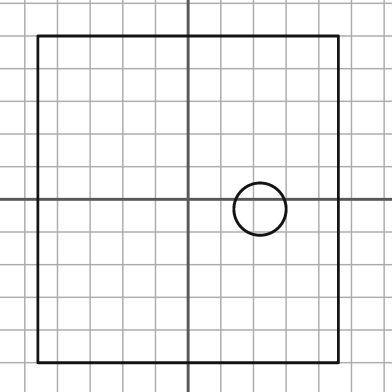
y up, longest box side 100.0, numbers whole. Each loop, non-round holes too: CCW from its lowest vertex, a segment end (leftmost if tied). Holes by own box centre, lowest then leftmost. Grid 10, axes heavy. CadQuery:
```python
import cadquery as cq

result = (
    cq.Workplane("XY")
    .moveTo(-46.0, -50.0)
    .lineTo(46.0, -50.0)
    .lineTo(46.0, 50.0)
    .lineTo(-46.0, 50.0)
    .close()
    .moveTo(22.0, -3.0)
    .circle(8.0)
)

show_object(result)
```